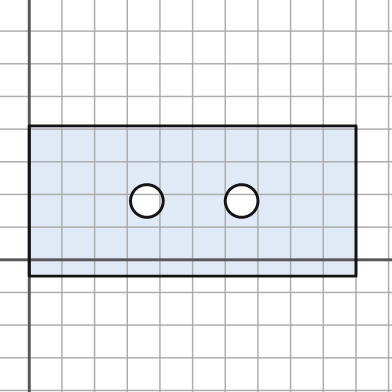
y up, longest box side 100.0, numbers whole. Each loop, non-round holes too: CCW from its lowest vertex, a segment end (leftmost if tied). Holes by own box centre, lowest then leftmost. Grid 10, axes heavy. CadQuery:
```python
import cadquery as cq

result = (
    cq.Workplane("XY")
    .moveTo(0.0, -5.0)
    .lineTo(100.0, -5.0)
    .lineTo(100.0, 41.0)
    .lineTo(0.0, 41.0)
    .close()
    .moveTo(36.0, 18.0)
    .circle(5.0)
    .moveTo(65.0, 18.0)
    .circle(5.0)
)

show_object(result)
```